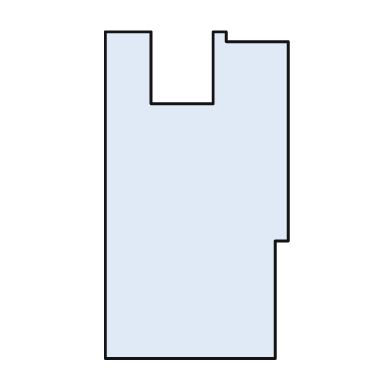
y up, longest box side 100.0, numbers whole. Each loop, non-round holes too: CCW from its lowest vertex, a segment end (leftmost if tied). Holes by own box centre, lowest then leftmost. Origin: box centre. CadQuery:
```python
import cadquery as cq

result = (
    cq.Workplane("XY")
    .moveTo(-28.0, -50.0)
    .lineTo(24.0, -50.0)
    .lineTo(24.0, -14.0)
    .lineTo(28.0, -14.0)
    .lineTo(28.0, 47.0)
    .lineTo(9.0, 47.0)
    .lineTo(9.0, 50.0)
    .lineTo(5.0, 50.0)
    .lineTo(5.0, 28.0)
    .lineTo(-14.0, 28.0)
    .lineTo(-14.0, 50.0)
    .lineTo(-28.0, 50.0)
    .close()
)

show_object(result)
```